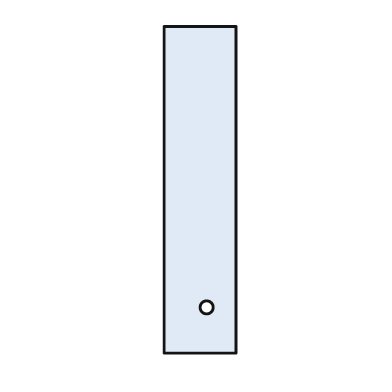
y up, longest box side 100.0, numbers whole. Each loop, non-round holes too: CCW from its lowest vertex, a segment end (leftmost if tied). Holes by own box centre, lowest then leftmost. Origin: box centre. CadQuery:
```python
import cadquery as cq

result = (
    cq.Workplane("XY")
    .moveTo(-11.0, -50.0)
    .lineTo(11.0, -50.0)
    .lineTo(11.0, 50.0)
    .lineTo(-11.0, 50.0)
    .close()
    .moveTo(2.0, -36.0)
    .circle(2.0)
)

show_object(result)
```